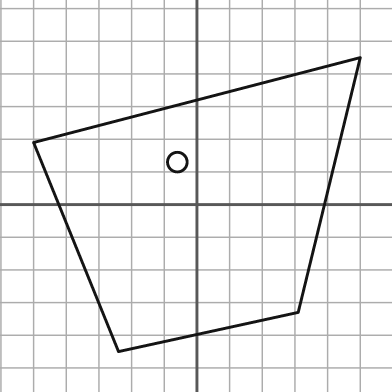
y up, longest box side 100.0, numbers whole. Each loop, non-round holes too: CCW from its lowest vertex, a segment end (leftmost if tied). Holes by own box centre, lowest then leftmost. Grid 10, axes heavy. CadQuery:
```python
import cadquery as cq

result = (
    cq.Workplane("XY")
    .moveTo(-24.0, -45.0)
    .lineTo(31.0, -33.0)
    .lineTo(50.0, 45.0)
    .lineTo(-50.0, 19.0)
    .close()
    .moveTo(-6.0, 13.0)
    .circle(3.0)
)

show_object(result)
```